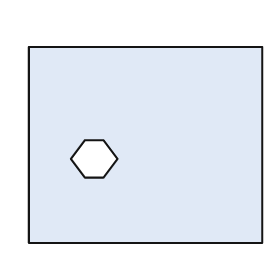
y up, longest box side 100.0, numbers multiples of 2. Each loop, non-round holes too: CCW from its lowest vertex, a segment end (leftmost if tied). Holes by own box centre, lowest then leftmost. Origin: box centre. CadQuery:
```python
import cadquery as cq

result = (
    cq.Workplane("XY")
    .moveTo(-50.0, -42.0)
    .lineTo(50.0, -42.0)
    .lineTo(50.0, 42.0)
    .lineTo(-50.0, 42.0)
    .close()
    .moveTo(-26.0, -14.0)
    .lineTo(-18.0, -14.0)
    .lineTo(-12.0, -6.0)
    .lineTo(-18.0, 2.0)
    .lineTo(-26.0, 2.0)
    .lineTo(-32.0, -6.0)
    .close()
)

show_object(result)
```